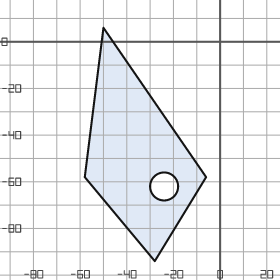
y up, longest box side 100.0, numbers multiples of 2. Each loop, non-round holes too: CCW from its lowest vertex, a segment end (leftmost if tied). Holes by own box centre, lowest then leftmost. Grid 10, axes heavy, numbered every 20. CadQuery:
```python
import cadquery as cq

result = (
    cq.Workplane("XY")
    .moveTo(-28.0, -94.0)
    .lineTo(-6.0, -58.0)
    .lineTo(-50.0, 6.0)
    .lineTo(-58.0, -58.0)
    .close()
    .moveTo(-24.0, -62.0)
    .circle(6.0)
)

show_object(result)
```